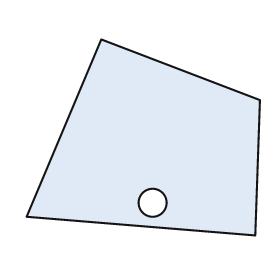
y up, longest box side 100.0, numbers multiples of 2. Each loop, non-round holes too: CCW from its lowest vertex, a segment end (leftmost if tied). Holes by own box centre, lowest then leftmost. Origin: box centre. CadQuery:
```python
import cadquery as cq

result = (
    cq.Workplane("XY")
    .moveTo(48.0, -42.0)
    .lineTo(50.0, 16.0)
    .lineTo(-18.0, 42.0)
    .lineTo(-50.0, -34.0)
    .close()
    .moveTo(4.0, -28.0)
    .circle(6.0)
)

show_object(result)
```